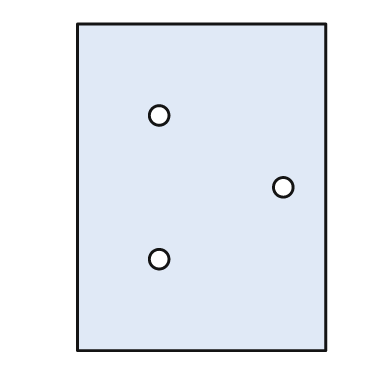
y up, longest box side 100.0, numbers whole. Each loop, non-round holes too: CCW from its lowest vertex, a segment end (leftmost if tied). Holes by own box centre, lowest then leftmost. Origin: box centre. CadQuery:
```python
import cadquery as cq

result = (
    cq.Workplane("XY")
    .moveTo(-38.0, -50.0)
    .lineTo(38.0, -50.0)
    .lineTo(38.0, 50.0)
    .lineTo(-38.0, 50.0)
    .close()
    .moveTo(-13.0, -22.0)
    .circle(3.0)
    .moveTo(25.0, 0.0)
    .circle(3.0)
    .moveTo(-13.0, 22.0)
    .circle(3.0)
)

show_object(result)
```